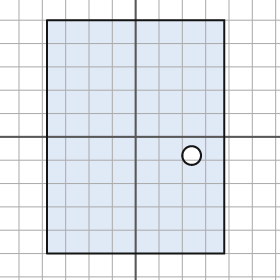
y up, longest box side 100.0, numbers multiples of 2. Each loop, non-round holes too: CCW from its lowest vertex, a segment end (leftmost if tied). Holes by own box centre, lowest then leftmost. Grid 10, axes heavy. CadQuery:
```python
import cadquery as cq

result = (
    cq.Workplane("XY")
    .moveTo(-38.0, -50.0)
    .lineTo(38.0, -50.0)
    .lineTo(38.0, 50.0)
    .lineTo(-38.0, 50.0)
    .close()
    .moveTo(24.0, -8.0)
    .circle(4.0)
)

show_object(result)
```